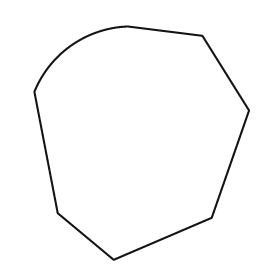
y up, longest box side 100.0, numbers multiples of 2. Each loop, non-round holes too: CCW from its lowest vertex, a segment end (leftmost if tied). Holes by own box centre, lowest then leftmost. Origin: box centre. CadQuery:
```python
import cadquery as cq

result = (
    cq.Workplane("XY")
    .moveTo(-12.0, -50.0)
    .lineTo(30.0, -32.0)
    .lineTo(46.0, 14.0)
    .lineTo(26.0, 46.0)
    .lineTo(-6.0, 50.0)
    .threePointArc((-30.0, 42.0), (-46.0, 22.0))
    .lineTo(-36.0, -30.0)
    .close()
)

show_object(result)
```